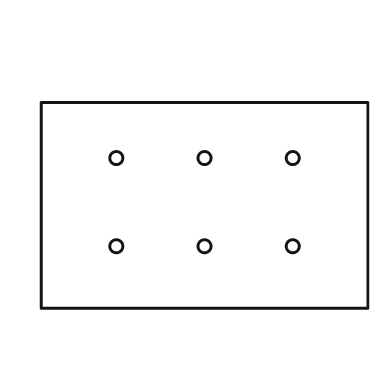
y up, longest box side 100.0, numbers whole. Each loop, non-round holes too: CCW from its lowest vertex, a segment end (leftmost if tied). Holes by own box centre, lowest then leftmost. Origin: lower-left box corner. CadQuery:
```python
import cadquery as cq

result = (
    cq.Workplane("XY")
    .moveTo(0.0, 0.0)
    .lineTo(100.0, 0.0)
    .lineTo(100.0, 63.0)
    .lineTo(0.0, 63.0)
    .close()
    .moveTo(23.0, 19.0)
    .circle(2.0)
    .moveTo(50.0, 19.0)
    .circle(2.0)
    .moveTo(77.0, 19.0)
    .circle(2.0)
    .moveTo(23.0, 46.0)
    .circle(2.0)
    .moveTo(50.0, 46.0)
    .circle(2.0)
    .moveTo(77.0, 46.0)
    .circle(2.0)
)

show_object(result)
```